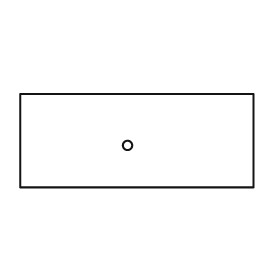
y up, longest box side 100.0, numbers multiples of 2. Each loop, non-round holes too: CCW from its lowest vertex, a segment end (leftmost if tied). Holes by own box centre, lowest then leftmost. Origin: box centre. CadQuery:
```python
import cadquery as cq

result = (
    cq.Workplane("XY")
    .moveTo(-50.0, -20.0)
    .lineTo(50.0, -20.0)
    .lineTo(50.0, 20.0)
    .lineTo(-50.0, 20.0)
    .close()
    .moveTo(-4.0, -2.0)
    .circle(2.0)
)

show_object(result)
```